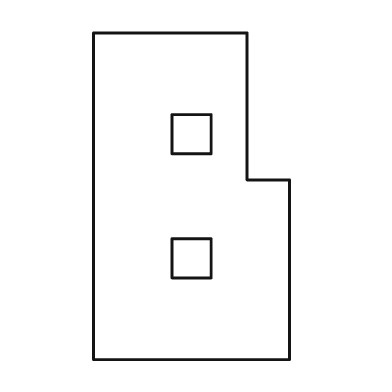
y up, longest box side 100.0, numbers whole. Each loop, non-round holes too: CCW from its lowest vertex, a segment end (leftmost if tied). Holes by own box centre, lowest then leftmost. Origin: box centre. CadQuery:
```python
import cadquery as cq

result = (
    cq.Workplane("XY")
    .moveTo(-30.0, -50.0)
    .lineTo(30.0, -50.0)
    .lineTo(30.0, 5.0)
    .lineTo(17.0, 5.0)
    .lineTo(17.0, 50.0)
    .lineTo(-30.0, 50.0)
    .close()
    .moveTo(-6.0, -25.0)
    .lineTo(6.0, -25.0)
    .lineTo(6.0, -13.0)
    .lineTo(-6.0, -13.0)
    .close()
    .moveTo(-6.0, 13.0)
    .lineTo(6.0, 13.0)
    .lineTo(6.0, 25.0)
    .lineTo(-6.0, 25.0)
    .close()
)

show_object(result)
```